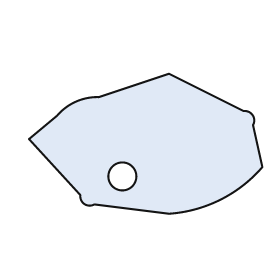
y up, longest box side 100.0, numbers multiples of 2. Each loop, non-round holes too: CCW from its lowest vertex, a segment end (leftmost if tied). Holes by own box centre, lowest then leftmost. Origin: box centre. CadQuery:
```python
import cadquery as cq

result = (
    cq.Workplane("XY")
    .moveTo(10.0, -30.0)
    .threePointArc((32.0, -24.0), (50.0, -10.0))
    .lineTo(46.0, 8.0)
    .threePointArc((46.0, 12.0), (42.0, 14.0))
    .lineTo(10.0, 30.0)
    .lineTo(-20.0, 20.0)
    .threePointArc((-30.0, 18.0), (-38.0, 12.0))
    .lineTo(-50.0, 2.0)
    .lineTo(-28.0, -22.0)
    .threePointArc((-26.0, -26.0), (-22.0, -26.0))
    .close()
    .moveTo(-10.0, -14.0)
    .circle(6.0)
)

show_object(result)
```